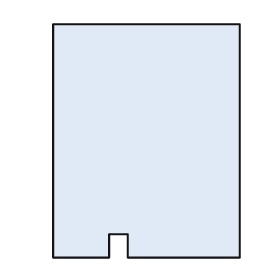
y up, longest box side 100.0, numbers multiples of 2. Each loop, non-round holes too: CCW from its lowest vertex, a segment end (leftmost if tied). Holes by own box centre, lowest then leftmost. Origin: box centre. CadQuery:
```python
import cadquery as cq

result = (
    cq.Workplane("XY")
    .moveTo(-40.0, -50.0)
    .lineTo(-16.0, -50.0)
    .lineTo(-16.0, -40.0)
    .lineTo(-8.0, -40.0)
    .lineTo(-8.0, -50.0)
    .lineTo(40.0, -50.0)
    .lineTo(40.0, 50.0)
    .lineTo(-40.0, 50.0)
    .close()
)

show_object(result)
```